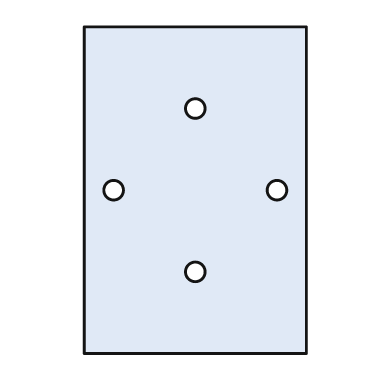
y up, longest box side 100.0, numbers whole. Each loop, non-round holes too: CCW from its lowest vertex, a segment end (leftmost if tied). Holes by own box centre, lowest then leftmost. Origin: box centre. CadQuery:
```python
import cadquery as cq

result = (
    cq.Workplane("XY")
    .moveTo(-34.0, -50.0)
    .lineTo(34.0, -50.0)
    .lineTo(34.0, 50.0)
    .lineTo(-34.0, 50.0)
    .close()
    .moveTo(0.0, -25.0)
    .circle(3.0)
    .moveTo(-25.0, 0.0)
    .circle(3.0)
    .moveTo(25.0, 0.0)
    .circle(3.0)
    .moveTo(0.0, 25.0)
    .circle(3.0)
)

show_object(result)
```